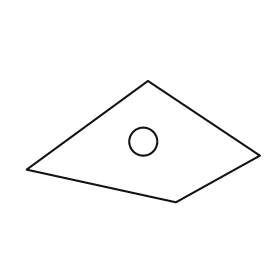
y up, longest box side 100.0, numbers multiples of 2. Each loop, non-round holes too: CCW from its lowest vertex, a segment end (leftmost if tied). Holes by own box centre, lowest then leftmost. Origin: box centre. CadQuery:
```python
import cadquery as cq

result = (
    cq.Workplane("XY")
    .moveTo(14.0, -26.0)
    .lineTo(50.0, -6.0)
    .lineTo(2.0, 26.0)
    .lineTo(-50.0, -12.0)
    .close()
    .moveTo(0.0, 0.0)
    .circle(6.0)
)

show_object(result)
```